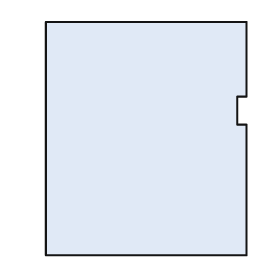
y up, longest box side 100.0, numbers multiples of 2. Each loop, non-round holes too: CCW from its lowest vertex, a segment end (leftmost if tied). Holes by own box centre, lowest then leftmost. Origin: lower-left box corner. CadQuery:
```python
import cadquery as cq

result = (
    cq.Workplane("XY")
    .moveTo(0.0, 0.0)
    .lineTo(86.0, 0.0)
    .lineTo(86.0, 56.0)
    .lineTo(82.0, 56.0)
    .lineTo(82.0, 68.0)
    .lineTo(86.0, 68.0)
    .lineTo(86.0, 100.0)
    .lineTo(0.0, 100.0)
    .close()
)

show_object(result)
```